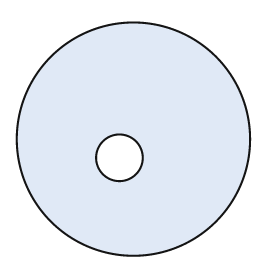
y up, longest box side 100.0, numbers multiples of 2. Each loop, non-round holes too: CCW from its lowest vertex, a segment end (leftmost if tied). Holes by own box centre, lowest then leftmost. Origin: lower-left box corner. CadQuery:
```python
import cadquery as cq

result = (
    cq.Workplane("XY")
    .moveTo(50.0, 50.0)
    .circle(50.0)
    .moveTo(44.0, 42.0)
    .circle(10.0)
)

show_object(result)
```